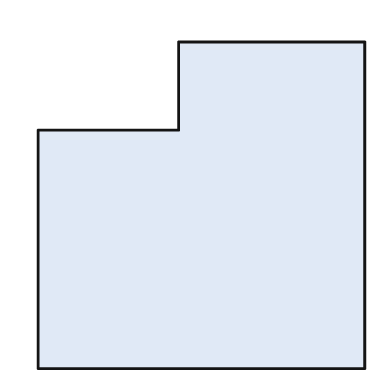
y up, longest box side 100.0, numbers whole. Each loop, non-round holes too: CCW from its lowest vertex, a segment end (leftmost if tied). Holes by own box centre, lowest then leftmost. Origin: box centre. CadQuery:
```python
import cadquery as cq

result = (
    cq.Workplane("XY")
    .moveTo(-50.0, -50.0)
    .lineTo(50.0, -50.0)
    .lineTo(50.0, 50.0)
    .lineTo(-7.0, 50.0)
    .lineTo(-7.0, 23.0)
    .lineTo(-50.0, 23.0)
    .close()
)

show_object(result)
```